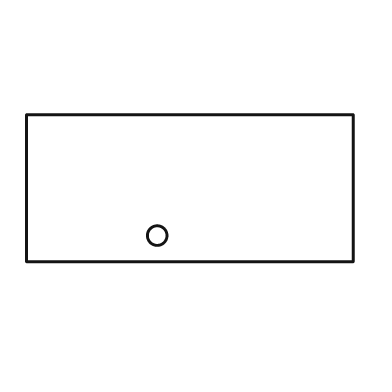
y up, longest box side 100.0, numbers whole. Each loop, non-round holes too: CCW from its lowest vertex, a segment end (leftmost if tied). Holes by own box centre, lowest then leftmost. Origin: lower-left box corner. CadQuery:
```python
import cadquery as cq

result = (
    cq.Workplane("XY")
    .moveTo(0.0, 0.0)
    .lineTo(100.0, 0.0)
    .lineTo(100.0, 45.0)
    .lineTo(0.0, 45.0)
    .close()
    .moveTo(40.0, 8.0)
    .circle(3.0)
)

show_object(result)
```